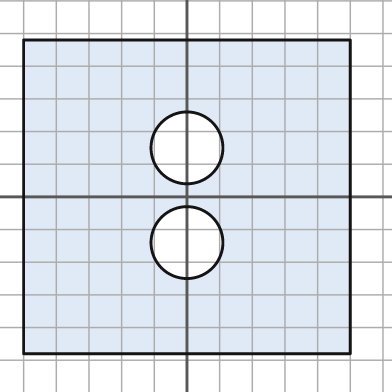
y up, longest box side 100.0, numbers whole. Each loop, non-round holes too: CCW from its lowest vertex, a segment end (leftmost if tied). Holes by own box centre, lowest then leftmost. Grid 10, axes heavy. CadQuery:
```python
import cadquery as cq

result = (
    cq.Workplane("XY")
    .moveTo(-50.0, -48.0)
    .lineTo(50.0, -48.0)
    .lineTo(50.0, 48.0)
    .lineTo(-50.0, 48.0)
    .close()
    .moveTo(0.0, -14.0)
    .circle(11.0)
    .moveTo(0.0, 15.0)
    .circle(11.0)
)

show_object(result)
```